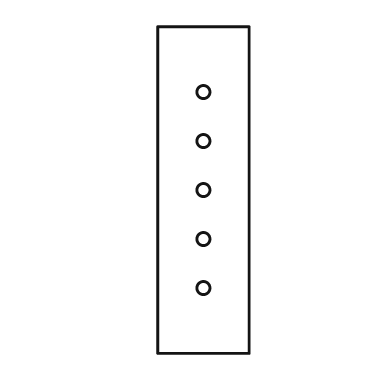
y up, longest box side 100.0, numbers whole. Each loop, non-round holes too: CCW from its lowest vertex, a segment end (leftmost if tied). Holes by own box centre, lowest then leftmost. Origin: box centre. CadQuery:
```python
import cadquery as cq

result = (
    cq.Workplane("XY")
    .moveTo(-14.0, -50.0)
    .lineTo(14.0, -50.0)
    .lineTo(14.0, 50.0)
    .lineTo(-14.0, 50.0)
    .close()
    .moveTo(0.0, -30.0)
    .circle(2.0)
    .moveTo(0.0, -15.0)
    .circle(2.0)
    .moveTo(0.0, 0.0)
    .circle(2.0)
    .moveTo(0.0, 15.0)
    .circle(2.0)
    .moveTo(0.0, 30.0)
    .circle(2.0)
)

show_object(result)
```